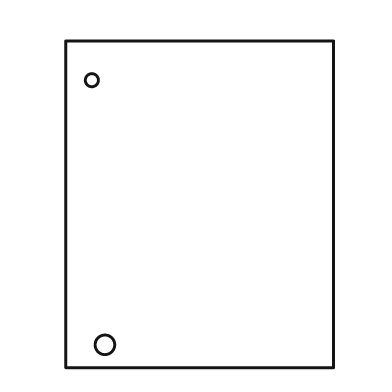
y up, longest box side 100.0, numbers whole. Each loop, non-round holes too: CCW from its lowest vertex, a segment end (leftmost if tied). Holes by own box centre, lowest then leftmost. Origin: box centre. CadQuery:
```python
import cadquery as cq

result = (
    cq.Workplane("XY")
    .moveTo(-41.0, -50.0)
    .lineTo(41.0, -50.0)
    .lineTo(41.0, 50.0)
    .lineTo(-41.0, 50.0)
    .close()
    .moveTo(-29.0, -43.0)
    .circle(3.0)
    .moveTo(-33.0, 38.0)
    .circle(2.0)
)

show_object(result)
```